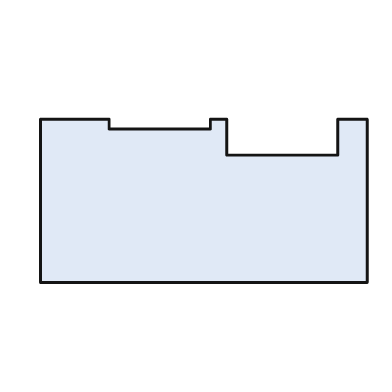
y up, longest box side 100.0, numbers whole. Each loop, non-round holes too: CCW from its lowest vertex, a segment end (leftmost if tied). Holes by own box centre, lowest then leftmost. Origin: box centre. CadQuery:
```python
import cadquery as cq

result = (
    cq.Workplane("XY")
    .moveTo(-50.0, -25.0)
    .lineTo(50.0, -25.0)
    .lineTo(50.0, 25.0)
    .lineTo(41.0, 25.0)
    .lineTo(41.0, 14.0)
    .lineTo(7.0, 14.0)
    .lineTo(7.0, 25.0)
    .lineTo(2.0, 25.0)
    .lineTo(2.0, 22.0)
    .lineTo(-29.0, 22.0)
    .lineTo(-29.0, 25.0)
    .lineTo(-50.0, 25.0)
    .close()
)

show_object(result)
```